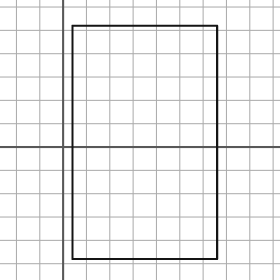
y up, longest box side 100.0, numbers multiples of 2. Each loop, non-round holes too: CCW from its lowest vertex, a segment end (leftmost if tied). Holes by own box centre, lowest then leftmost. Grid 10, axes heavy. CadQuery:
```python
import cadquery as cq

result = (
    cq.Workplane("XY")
    .moveTo(4.0, -48.0)
    .lineTo(66.0, -48.0)
    .lineTo(66.0, 52.0)
    .lineTo(4.0, 52.0)
    .close()
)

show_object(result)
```